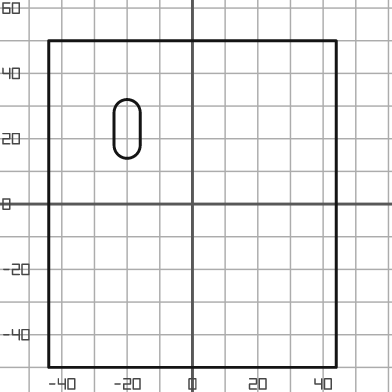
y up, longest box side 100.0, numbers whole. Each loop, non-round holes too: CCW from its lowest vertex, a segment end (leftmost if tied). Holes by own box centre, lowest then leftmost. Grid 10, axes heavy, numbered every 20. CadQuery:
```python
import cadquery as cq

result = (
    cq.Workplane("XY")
    .moveTo(-44.0, -50.0)
    .lineTo(44.0, -50.0)
    .lineTo(44.0, 50.0)
    .lineTo(-44.0, 50.0)
    .close()
    .moveTo(-24.0, 18.0)
    .threePointArc((-20.0, 14.0), (-16.0, 18.0))
    .lineTo(-16.0, 28.0)
    .threePointArc((-20.0, 32.0), (-24.0, 28.0))
    .close()
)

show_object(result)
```